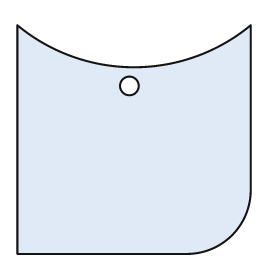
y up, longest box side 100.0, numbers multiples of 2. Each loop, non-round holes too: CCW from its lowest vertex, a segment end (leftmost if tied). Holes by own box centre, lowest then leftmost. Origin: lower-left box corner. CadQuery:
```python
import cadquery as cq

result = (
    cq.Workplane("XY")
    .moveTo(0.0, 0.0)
    .lineTo(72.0, 0.0)
    .threePointArc((92.0, 8.0), (100.0, 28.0))
    .lineTo(100.0, 98.0)
    .threePointArc((50.0, 80.0), (0.0, 98.0))
    .close()
    .moveTo(48.0, 72.0)
    .circle(4.0)
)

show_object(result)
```